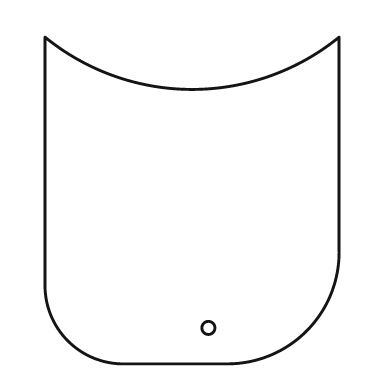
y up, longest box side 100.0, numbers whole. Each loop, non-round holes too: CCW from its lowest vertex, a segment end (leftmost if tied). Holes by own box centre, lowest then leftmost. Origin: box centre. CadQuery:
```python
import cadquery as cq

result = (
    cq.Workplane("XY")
    .moveTo(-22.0, -50.0)
    .lineTo(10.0, -50.0)
    .threePointArc((35.0, -40.0), (45.0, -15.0))
    .lineTo(45.0, 50.0)
    .threePointArc((0.0, 34.0), (-45.0, 50.0))
    .lineTo(-45.0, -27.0)
    .threePointArc((-38.0, -43.0), (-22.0, -50.0))
    .close()
    .moveTo(5.0, -39.0)
    .circle(2.0)
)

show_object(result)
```